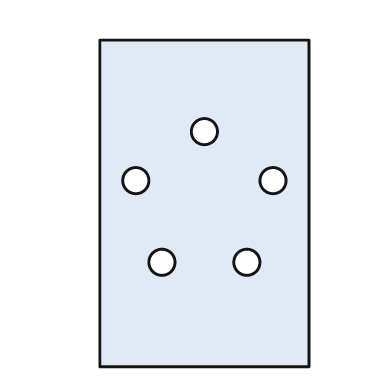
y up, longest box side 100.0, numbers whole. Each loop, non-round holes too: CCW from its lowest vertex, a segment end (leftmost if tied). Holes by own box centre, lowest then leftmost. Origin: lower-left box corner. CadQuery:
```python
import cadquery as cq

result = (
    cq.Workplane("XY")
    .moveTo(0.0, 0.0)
    .lineTo(64.0, 0.0)
    .lineTo(64.0, 100.0)
    .lineTo(0.0, 100.0)
    .close()
    .moveTo(19.0, 32.0)
    .circle(4.0)
    .moveTo(45.0, 32.0)
    .circle(4.0)
    .moveTo(11.0, 57.0)
    .circle(4.0)
    .moveTo(53.0, 57.0)
    .circle(4.0)
    .moveTo(32.0, 72.0)
    .circle(4.0)
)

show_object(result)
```